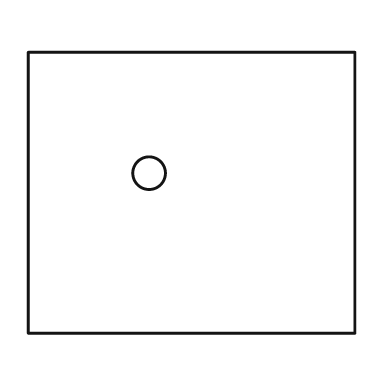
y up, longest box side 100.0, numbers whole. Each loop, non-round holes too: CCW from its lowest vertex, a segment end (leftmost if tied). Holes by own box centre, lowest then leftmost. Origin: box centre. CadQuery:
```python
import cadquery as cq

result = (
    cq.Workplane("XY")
    .moveTo(-50.0, -43.0)
    .lineTo(50.0, -43.0)
    .lineTo(50.0, 43.0)
    .lineTo(-50.0, 43.0)
    .close()
    .moveTo(-13.0, 6.0)
    .circle(5.0)
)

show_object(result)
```